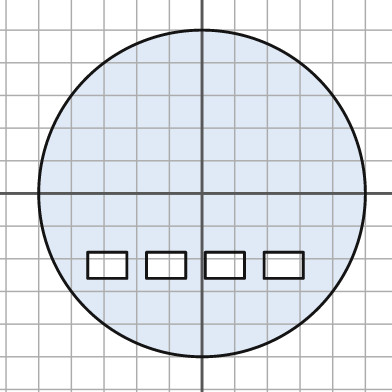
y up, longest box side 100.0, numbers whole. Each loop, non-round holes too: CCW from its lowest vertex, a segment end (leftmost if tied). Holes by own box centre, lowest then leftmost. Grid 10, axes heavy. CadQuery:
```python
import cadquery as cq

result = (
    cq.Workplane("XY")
    .moveTo(0.0, 0.0)
    .circle(50.0)
    .moveTo(-35.0, -26.0)
    .lineTo(-23.0, -26.0)
    .lineTo(-23.0, -18.0)
    .lineTo(-35.0, -18.0)
    .close()
    .moveTo(-17.0, -26.0)
    .lineTo(-5.0, -26.0)
    .lineTo(-5.0, -18.0)
    .lineTo(-17.0, -18.0)
    .close()
    .moveTo(1.0, -26.0)
    .lineTo(13.0, -26.0)
    .lineTo(13.0, -18.0)
    .lineTo(1.0, -18.0)
    .close()
    .moveTo(19.0, -26.0)
    .lineTo(31.0, -26.0)
    .lineTo(31.0, -18.0)
    .lineTo(19.0, -18.0)
    .close()
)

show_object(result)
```